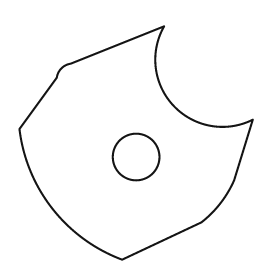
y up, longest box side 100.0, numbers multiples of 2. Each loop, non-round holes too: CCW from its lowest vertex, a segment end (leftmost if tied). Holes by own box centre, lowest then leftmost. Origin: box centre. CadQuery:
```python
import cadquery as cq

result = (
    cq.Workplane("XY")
    .moveTo(-6.0, -50.0)
    .lineTo(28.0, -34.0)
    .threePointArc((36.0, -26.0), (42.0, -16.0))
    .lineTo(50.0, 10.0)
    .threePointArc((16.0, 16.0), (12.0, 50.0))
    .lineTo(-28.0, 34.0)
    .threePointArc((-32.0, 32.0), (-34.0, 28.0))
    .lineTo(-50.0, 6.0)
    .threePointArc((-36.0, -28.0), (-6.0, -50.0))
    .close()
    .moveTo(0.0, -6.0)
    .circle(10.0)
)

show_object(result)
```